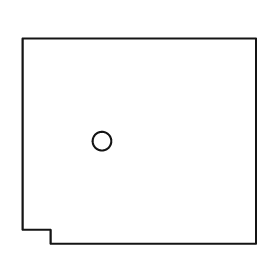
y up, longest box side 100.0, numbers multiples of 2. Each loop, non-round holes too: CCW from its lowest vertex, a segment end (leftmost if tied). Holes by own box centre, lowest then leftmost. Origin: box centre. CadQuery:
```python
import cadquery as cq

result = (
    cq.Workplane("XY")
    .moveTo(-38.0, -44.0)
    .lineTo(50.0, -44.0)
    .lineTo(50.0, 44.0)
    .lineTo(-50.0, 44.0)
    .lineTo(-50.0, -38.0)
    .lineTo(-38.0, -38.0)
    .close()
    .moveTo(-16.0, 0.0)
    .circle(4.0)
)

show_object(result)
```